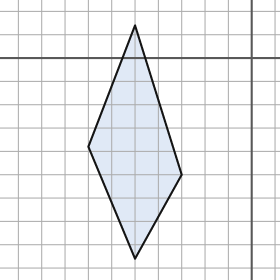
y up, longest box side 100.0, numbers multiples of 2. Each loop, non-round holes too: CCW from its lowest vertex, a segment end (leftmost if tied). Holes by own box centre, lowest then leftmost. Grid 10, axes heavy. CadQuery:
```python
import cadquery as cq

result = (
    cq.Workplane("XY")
    .moveTo(-50.0, -86.0)
    .lineTo(-30.0, -50.0)
    .lineTo(-50.0, 14.0)
    .lineTo(-70.0, -38.0)
    .close()
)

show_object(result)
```